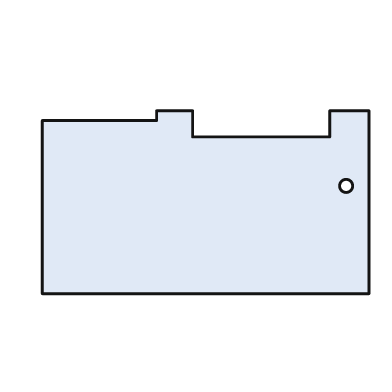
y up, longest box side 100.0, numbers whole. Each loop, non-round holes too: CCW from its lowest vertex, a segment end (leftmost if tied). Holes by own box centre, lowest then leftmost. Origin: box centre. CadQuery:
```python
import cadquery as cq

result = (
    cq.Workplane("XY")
    .moveTo(-50.0, -28.0)
    .lineTo(50.0, -28.0)
    .lineTo(50.0, 28.0)
    .lineTo(38.0, 28.0)
    .lineTo(38.0, 20.0)
    .lineTo(-4.0, 20.0)
    .lineTo(-4.0, 28.0)
    .lineTo(-15.0, 28.0)
    .lineTo(-15.0, 25.0)
    .lineTo(-50.0, 25.0)
    .close()
    .moveTo(43.0, 5.0)
    .circle(2.0)
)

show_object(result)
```